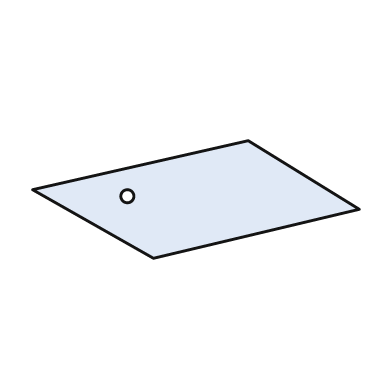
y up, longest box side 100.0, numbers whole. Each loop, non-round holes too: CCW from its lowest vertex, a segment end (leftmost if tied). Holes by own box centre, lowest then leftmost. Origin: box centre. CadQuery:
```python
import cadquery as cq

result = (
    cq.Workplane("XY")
    .moveTo(-13.0, -18.0)
    .lineTo(50.0, -3.0)
    .lineTo(16.0, 18.0)
    .lineTo(-50.0, 3.0)
    .close()
    .moveTo(-21.0, 1.0)
    .circle(2.0)
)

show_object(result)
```